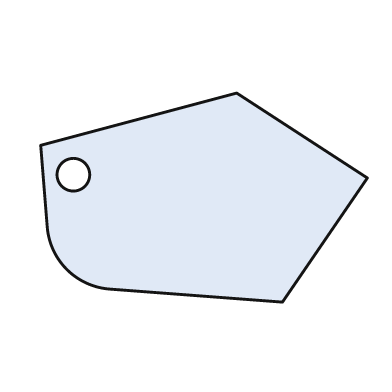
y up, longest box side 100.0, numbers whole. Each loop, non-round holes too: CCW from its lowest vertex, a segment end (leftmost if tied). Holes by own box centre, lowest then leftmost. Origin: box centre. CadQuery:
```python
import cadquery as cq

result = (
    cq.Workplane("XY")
    .moveTo(24.0, -32.0)
    .lineTo(50.0, 6.0)
    .lineTo(10.0, 32.0)
    .lineTo(-50.0, 16.0)
    .lineTo(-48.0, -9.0)
    .threePointArc((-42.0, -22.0), (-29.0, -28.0))
    .close()
    .moveTo(-40.0, 7.0)
    .circle(5.0)
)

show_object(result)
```